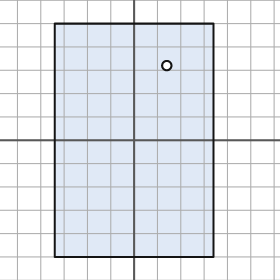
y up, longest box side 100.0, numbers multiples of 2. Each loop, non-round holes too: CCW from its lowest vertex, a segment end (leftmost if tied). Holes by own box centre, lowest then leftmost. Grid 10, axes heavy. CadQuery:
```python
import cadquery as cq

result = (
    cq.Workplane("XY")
    .moveTo(-34.0, -50.0)
    .lineTo(34.0, -50.0)
    .lineTo(34.0, 50.0)
    .lineTo(-34.0, 50.0)
    .close()
    .moveTo(14.0, 32.0)
    .circle(2.0)
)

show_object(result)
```